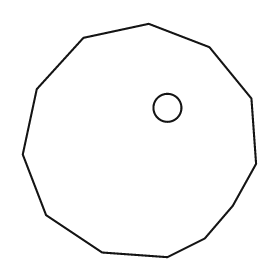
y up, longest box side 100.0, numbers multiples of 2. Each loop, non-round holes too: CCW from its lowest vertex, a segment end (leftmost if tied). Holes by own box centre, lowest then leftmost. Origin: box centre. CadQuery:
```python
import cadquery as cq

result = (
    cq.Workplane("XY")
    .moveTo(12.0, -50.0)
    .lineTo(28.0, -42.0)
    .lineTo(40.0, -28.0)
    .lineTo(50.0, -10.0)
    .lineTo(48.0, 18.0)
    .lineTo(30.0, 40.0)
    .lineTo(4.0, 50.0)
    .lineTo(-24.0, 44.0)
    .lineTo(-44.0, 22.0)
    .lineTo(-50.0, -6.0)
    .lineTo(-40.0, -32.0)
    .lineTo(-16.0, -48.0)
    .close()
    .moveTo(12.0, 14.0)
    .circle(6.0)
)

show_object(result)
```